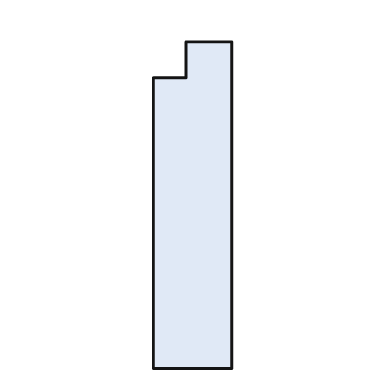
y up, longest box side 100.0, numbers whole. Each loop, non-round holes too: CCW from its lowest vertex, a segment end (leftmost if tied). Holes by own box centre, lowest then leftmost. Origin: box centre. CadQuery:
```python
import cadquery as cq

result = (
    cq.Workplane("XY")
    .moveTo(-12.0, -50.0)
    .lineTo(12.0, -50.0)
    .lineTo(12.0, 50.0)
    .lineTo(-2.0, 50.0)
    .lineTo(-2.0, 39.0)
    .lineTo(-12.0, 39.0)
    .close()
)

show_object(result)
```